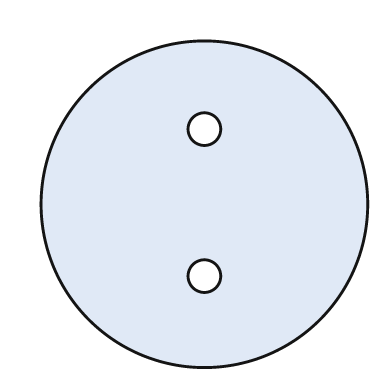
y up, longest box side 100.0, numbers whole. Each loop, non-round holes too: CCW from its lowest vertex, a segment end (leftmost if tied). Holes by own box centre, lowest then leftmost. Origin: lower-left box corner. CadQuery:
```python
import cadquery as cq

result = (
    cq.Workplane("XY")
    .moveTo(50.0, 50.0)
    .circle(50.0)
    .moveTo(50.0, 28.0)
    .circle(5.0)
    .moveTo(50.0, 73.0)
    .circle(5.0)
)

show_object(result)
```